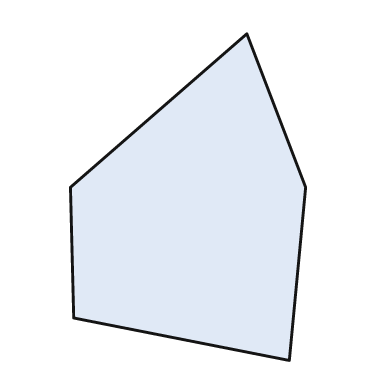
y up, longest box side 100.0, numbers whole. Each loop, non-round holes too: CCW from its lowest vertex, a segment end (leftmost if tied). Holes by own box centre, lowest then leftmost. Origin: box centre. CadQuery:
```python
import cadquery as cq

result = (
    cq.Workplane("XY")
    .moveTo(31.0, -50.0)
    .lineTo(36.0, 3.0)
    .lineTo(18.0, 50.0)
    .lineTo(-36.0, 3.0)
    .lineTo(-35.0, -37.0)
    .close()
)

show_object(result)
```